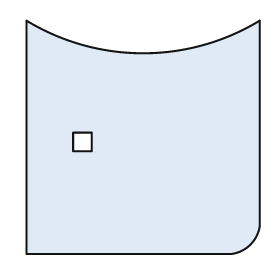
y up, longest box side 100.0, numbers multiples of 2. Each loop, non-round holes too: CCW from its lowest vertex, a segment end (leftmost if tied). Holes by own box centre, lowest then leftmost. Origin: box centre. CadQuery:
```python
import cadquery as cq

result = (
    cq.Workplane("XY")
    .moveTo(-50.0, -50.0)
    .lineTo(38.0, -50.0)
    .threePointArc((46.0, -46.0), (50.0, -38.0))
    .lineTo(50.0, 50.0)
    .threePointArc((0.0, 36.0), (-50.0, 50.0))
    .close()
    .moveTo(-30.0, -6.0)
    .lineTo(-22.0, -6.0)
    .lineTo(-22.0, 2.0)
    .lineTo(-30.0, 2.0)
    .close()
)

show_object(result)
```